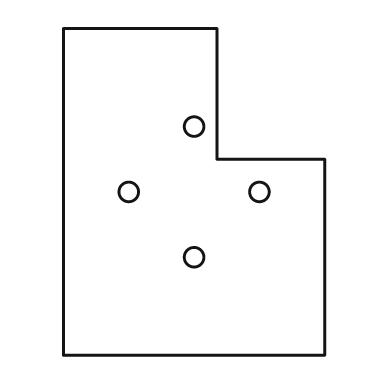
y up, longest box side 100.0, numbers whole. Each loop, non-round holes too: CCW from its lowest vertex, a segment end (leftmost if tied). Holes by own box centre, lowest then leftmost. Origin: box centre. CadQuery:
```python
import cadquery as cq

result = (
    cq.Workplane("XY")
    .moveTo(-40.0, -50.0)
    .lineTo(40.0, -50.0)
    .lineTo(40.0, 10.0)
    .lineTo(7.0, 10.0)
    .lineTo(7.0, 50.0)
    .lineTo(-40.0, 50.0)
    .close()
    .moveTo(0.0, -20.0)
    .circle(3.0)
    .moveTo(-20.0, 0.0)
    .circle(3.0)
    .moveTo(20.0, 0.0)
    .circle(3.0)
    .moveTo(0.0, 20.0)
    .circle(3.0)
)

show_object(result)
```